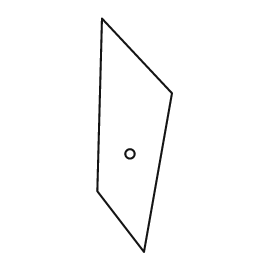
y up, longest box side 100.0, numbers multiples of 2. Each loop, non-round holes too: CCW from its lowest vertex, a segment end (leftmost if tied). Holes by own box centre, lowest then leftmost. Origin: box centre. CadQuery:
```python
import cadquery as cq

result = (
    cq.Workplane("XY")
    .moveTo(4.0, -50.0)
    .lineTo(16.0, 18.0)
    .lineTo(-14.0, 50.0)
    .lineTo(-16.0, -24.0)
    .close()
    .moveTo(-2.0, -8.0)
    .circle(2.0)
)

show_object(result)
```